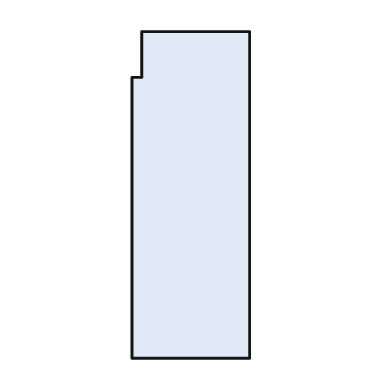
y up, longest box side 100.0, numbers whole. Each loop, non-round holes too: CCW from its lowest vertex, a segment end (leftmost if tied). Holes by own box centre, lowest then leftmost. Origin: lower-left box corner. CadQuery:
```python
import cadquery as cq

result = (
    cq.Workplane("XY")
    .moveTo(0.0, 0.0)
    .lineTo(36.0, 0.0)
    .lineTo(36.0, 100.0)
    .lineTo(3.0, 100.0)
    .lineTo(3.0, 86.0)
    .lineTo(0.0, 86.0)
    .close()
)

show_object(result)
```